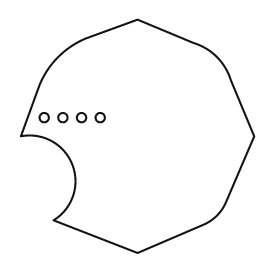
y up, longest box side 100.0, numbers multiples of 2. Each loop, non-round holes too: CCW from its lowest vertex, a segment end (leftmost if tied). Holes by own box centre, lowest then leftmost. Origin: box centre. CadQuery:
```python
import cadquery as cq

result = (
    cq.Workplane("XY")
    .moveTo(0.0, -50.0)
    .lineTo(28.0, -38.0)
    .threePointArc((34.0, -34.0), (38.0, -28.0))
    .lineTo(50.0, 0.0)
    .lineTo(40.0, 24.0)
    .threePointArc((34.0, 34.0), (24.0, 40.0))
    .lineTo(0.0, 50.0)
    .lineTo(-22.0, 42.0)
    .threePointArc((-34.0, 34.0), (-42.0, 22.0))
    .lineTo(-50.0, 0.0)
    .threePointArc((-28.0, -12.0), (-36.0, -36.0))
    .close()
    .moveTo(-40.0, 8.0)
    .circle(2.0)
    .moveTo(-32.0, 8.0)
    .circle(2.0)
    .moveTo(-24.0, 8.0)
    .circle(2.0)
    .moveTo(-16.0, 8.0)
    .circle(2.0)
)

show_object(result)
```